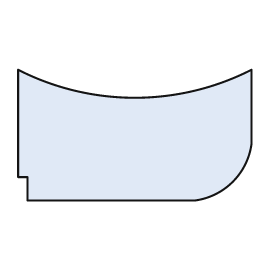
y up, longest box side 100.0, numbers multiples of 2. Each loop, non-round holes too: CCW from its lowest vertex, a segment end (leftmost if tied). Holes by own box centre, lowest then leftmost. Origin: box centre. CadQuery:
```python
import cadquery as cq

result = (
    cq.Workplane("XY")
    .moveTo(-46.0, -28.0)
    .lineTo(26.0, -28.0)
    .threePointArc((42.0, -20.0), (50.0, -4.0))
    .lineTo(50.0, 28.0)
    .threePointArc((0.0, 16.0), (-50.0, 28.0))
    .lineTo(-50.0, -18.0)
    .lineTo(-46.0, -18.0)
    .close()
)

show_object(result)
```